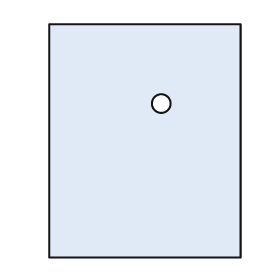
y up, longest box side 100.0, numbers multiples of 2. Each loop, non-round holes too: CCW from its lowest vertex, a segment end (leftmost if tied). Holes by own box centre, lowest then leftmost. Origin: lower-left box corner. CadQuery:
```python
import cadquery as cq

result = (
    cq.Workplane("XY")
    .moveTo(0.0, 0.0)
    .lineTo(82.0, 0.0)
    .lineTo(82.0, 100.0)
    .lineTo(0.0, 100.0)
    .close()
    .moveTo(48.0, 66.0)
    .circle(4.0)
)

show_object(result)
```